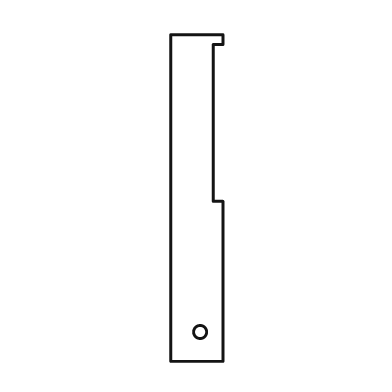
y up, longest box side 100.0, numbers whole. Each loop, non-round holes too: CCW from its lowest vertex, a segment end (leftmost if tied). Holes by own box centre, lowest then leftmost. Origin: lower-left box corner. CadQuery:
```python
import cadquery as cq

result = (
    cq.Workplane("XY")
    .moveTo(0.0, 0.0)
    .lineTo(16.0, 0.0)
    .lineTo(16.0, 49.0)
    .lineTo(13.0, 49.0)
    .lineTo(13.0, 97.0)
    .lineTo(16.0, 97.0)
    .lineTo(16.0, 100.0)
    .lineTo(0.0, 100.0)
    .close()
    .moveTo(9.0, 9.0)
    .circle(2.0)
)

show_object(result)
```